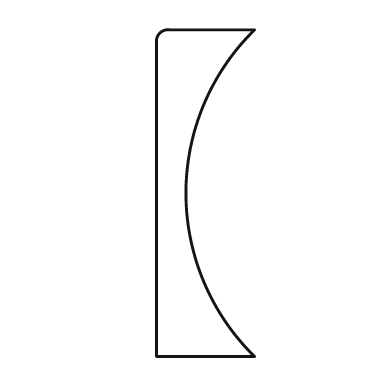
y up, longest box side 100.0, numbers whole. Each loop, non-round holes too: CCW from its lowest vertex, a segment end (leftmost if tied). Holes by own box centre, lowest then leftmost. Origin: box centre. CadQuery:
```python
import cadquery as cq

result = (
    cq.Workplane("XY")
    .moveTo(-15.0, -50.0)
    .lineTo(15.0, -50.0)
    .threePointArc((-6.0, 0.0), (15.0, 50.0))
    .lineTo(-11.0, 50.0)
    .threePointArc((-14.0, 49.0), (-15.0, 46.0))
    .close()
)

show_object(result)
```